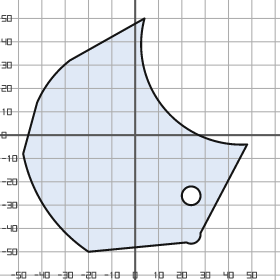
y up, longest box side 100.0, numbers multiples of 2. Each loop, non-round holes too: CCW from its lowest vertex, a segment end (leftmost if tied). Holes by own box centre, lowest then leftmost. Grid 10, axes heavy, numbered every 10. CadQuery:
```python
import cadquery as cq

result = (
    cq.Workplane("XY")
    .moveTo(-20.0, -50.0)
    .lineTo(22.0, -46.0)
    .threePointArc((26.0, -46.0), (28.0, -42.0))
    .lineTo(48.0, -4.0)
    .threePointArc((12.0, 12.0), (4.0, 50.0))
    .lineTo(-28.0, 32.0)
    .threePointArc((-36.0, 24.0), (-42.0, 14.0))
    .lineTo(-48.0, -8.0)
    .threePointArc((-38.0, -32.0), (-20.0, -50.0))
    .close()
    .moveTo(24.0, -26.0)
    .circle(4.0)
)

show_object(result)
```